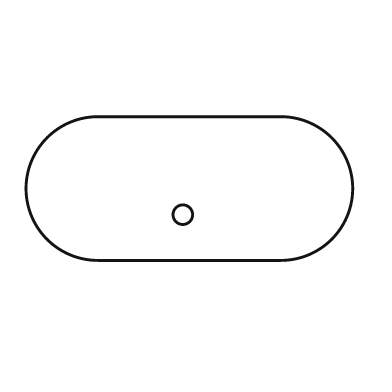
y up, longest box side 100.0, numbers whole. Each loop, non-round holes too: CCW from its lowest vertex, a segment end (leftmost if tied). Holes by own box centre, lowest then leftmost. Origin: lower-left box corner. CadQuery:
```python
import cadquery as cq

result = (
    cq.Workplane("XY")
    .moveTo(22.0, 0.0)
    .lineTo(78.0, 0.0)
    .threePointArc((100.0, 22.0), (78.0, 44.0))
    .lineTo(22.0, 44.0)
    .threePointArc((0.0, 22.0), (22.0, 0.0))
    .close()
    .moveTo(48.0, 14.0)
    .circle(3.0)
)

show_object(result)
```